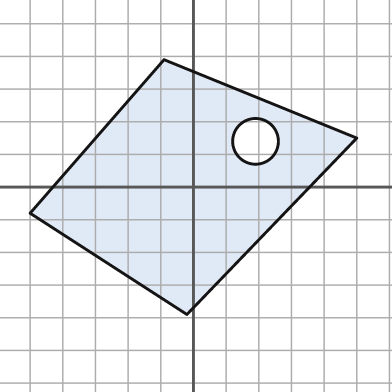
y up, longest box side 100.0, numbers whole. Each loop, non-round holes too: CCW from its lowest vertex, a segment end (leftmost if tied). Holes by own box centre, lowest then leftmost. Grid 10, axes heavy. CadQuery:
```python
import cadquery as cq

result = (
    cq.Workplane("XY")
    .moveTo(-2.0, -39.0)
    .lineTo(50.0, 15.0)
    .lineTo(-9.0, 39.0)
    .lineTo(-50.0, -8.0)
    .close()
    .moveTo(19.0, 14.0)
    .circle(7.0)
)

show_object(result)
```